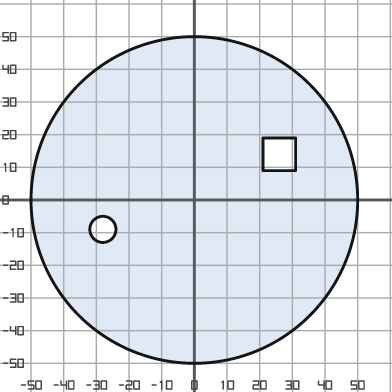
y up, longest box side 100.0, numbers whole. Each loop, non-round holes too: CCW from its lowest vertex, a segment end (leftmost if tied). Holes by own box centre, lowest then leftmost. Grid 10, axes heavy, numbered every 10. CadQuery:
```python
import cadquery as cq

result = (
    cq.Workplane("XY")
    .moveTo(0.0, 0.0)
    .circle(50.0)
    .moveTo(-28.0, -9.0)
    .circle(4.0)
    .moveTo(21.0, 9.0)
    .lineTo(31.0, 9.0)
    .lineTo(31.0, 19.0)
    .lineTo(21.0, 19.0)
    .close()
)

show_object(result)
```